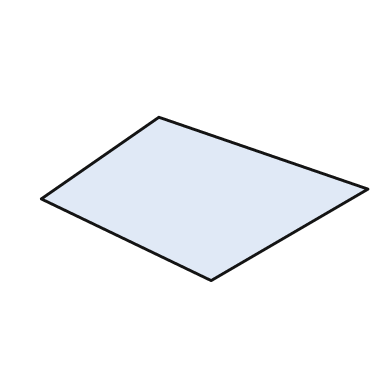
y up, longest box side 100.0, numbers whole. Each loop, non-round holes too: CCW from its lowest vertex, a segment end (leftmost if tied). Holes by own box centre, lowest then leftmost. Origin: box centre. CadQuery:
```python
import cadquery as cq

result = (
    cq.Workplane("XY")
    .moveTo(2.0, -25.0)
    .lineTo(50.0, 3.0)
    .lineTo(-14.0, 25.0)
    .lineTo(-50.0, 0.0)
    .close()
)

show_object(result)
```